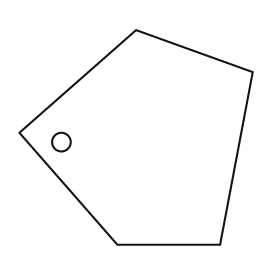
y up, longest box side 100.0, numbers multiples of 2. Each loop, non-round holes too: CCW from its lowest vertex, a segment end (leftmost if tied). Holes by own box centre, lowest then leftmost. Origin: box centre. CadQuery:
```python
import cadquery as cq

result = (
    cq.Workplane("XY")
    .moveTo(-8.0, -46.0)
    .lineTo(36.0, -46.0)
    .lineTo(50.0, 28.0)
    .lineTo(0.0, 46.0)
    .lineTo(-50.0, 2.0)
    .close()
    .moveTo(-32.0, -2.0)
    .circle(4.0)
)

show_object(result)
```